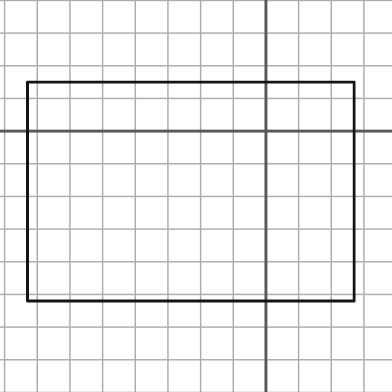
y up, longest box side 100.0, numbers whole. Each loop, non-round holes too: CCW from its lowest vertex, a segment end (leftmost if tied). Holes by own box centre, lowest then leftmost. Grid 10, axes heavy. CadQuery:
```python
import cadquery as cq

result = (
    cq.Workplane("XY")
    .moveTo(-73.0, -52.0)
    .lineTo(27.0, -52.0)
    .lineTo(27.0, 15.0)
    .lineTo(-73.0, 15.0)
    .close()
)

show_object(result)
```